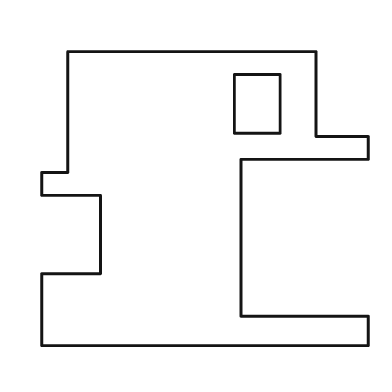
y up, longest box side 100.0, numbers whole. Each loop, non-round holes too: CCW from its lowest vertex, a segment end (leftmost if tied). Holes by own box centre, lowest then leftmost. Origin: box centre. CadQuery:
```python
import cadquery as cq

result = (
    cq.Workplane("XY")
    .moveTo(-50.0, -45.0)
    .lineTo(50.0, -45.0)
    .lineTo(50.0, -36.0)
    .lineTo(11.0, -36.0)
    .lineTo(11.0, 12.0)
    .lineTo(50.0, 12.0)
    .lineTo(50.0, 19.0)
    .lineTo(34.0, 19.0)
    .lineTo(34.0, 45.0)
    .lineTo(-42.0, 45.0)
    .lineTo(-42.0, 8.0)
    .lineTo(-50.0, 8.0)
    .lineTo(-50.0, 1.0)
    .lineTo(-32.0, 1.0)
    .lineTo(-32.0, -23.0)
    .lineTo(-50.0, -23.0)
    .close()
    .moveTo(9.0, 20.0)
    .lineTo(23.0, 20.0)
    .lineTo(23.0, 38.0)
    .lineTo(9.0, 38.0)
    .close()
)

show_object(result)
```